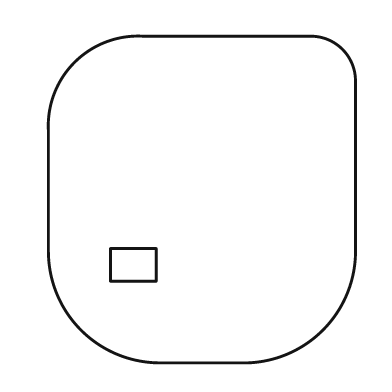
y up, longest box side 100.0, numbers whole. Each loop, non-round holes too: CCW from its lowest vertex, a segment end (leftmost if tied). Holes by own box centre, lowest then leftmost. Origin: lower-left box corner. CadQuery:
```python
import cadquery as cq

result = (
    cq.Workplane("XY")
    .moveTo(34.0, 0.0)
    .lineTo(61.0, 0.0)
    .threePointArc((84.0, 10.0), (94.0, 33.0))
    .lineTo(94.0, 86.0)
    .threePointArc((90.0, 96.0), (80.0, 100.0))
    .lineTo(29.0, 100.0)
    .threePointArc((8.0, 92.0), (0.0, 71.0))
    .lineTo(0.0, 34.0)
    .threePointArc((10.0, 10.0), (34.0, 0.0))
    .close()
    .moveTo(19.0, 25.0)
    .lineTo(33.0, 25.0)
    .lineTo(33.0, 35.0)
    .lineTo(19.0, 35.0)
    .close()
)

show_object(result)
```